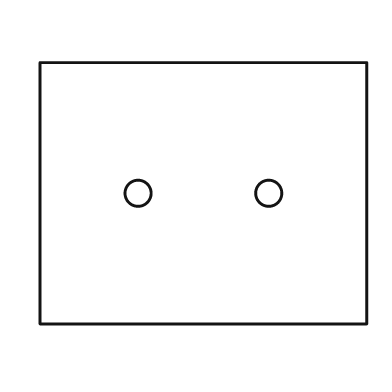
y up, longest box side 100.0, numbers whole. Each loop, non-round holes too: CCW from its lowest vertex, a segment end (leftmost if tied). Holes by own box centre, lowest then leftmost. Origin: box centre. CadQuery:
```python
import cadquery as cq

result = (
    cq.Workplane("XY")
    .moveTo(-50.0, -40.0)
    .lineTo(50.0, -40.0)
    .lineTo(50.0, 40.0)
    .lineTo(-50.0, 40.0)
    .close()
    .moveTo(-20.0, 0.0)
    .circle(4.0)
    .moveTo(20.0, 0.0)
    .circle(4.0)
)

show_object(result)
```